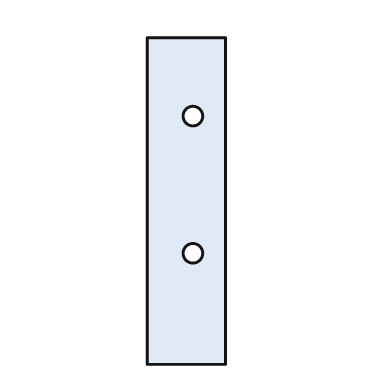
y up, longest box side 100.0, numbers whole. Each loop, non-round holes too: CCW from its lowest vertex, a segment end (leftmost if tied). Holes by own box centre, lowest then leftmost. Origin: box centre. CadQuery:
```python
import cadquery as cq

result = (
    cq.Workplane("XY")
    .moveTo(-12.0, -50.0)
    .lineTo(12.0, -50.0)
    .lineTo(12.0, 50.0)
    .lineTo(-12.0, 50.0)
    .close()
    .moveTo(2.0, -16.0)
    .circle(3.0)
    .moveTo(2.0, 26.0)
    .circle(3.0)
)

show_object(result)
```